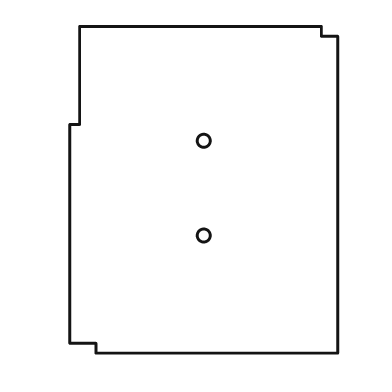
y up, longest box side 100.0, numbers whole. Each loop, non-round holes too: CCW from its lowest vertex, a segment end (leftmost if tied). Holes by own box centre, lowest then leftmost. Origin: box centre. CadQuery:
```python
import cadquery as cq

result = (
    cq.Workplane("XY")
    .moveTo(-33.0, -50.0)
    .lineTo(41.0, -50.0)
    .lineTo(41.0, 47.0)
    .lineTo(36.0, 47.0)
    .lineTo(36.0, 50.0)
    .lineTo(-38.0, 50.0)
    .lineTo(-38.0, 20.0)
    .lineTo(-41.0, 20.0)
    .lineTo(-41.0, -47.0)
    .lineTo(-33.0, -47.0)
    .close()
    .moveTo(0.0, -14.0)
    .circle(2.0)
    .moveTo(0.0, 15.0)
    .circle(2.0)
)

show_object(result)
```